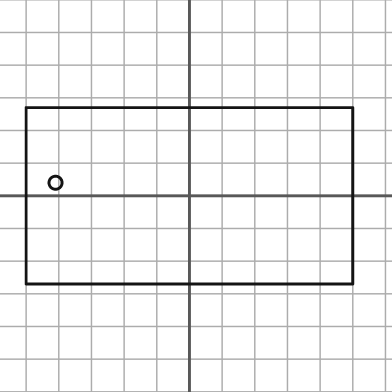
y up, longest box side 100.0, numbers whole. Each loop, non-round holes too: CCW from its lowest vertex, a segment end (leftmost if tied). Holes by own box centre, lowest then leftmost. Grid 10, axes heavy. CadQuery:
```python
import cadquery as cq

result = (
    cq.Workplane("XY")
    .moveTo(-50.0, -27.0)
    .lineTo(50.0, -27.0)
    .lineTo(50.0, 27.0)
    .lineTo(-50.0, 27.0)
    .close()
    .moveTo(-41.0, 4.0)
    .circle(2.0)
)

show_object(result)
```